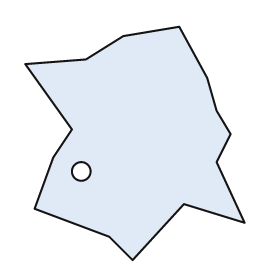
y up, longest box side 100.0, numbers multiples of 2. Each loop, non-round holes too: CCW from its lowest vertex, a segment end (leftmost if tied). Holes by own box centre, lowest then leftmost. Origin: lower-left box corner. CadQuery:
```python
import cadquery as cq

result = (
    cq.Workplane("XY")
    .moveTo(46.0, 0.0)
    .lineTo(68.0, 24.0)
    .lineTo(94.0, 16.0)
    .lineTo(82.0, 42.0)
    .lineTo(88.0, 54.0)
    .lineTo(82.0, 64.0)
    .lineTo(78.0, 78.0)
    .lineTo(66.0, 100.0)
    .lineTo(42.0, 96.0)
    .lineTo(26.0, 86.0)
    .lineTo(0.0, 84.0)
    .lineTo(20.0, 56.0)
    .lineTo(12.0, 44.0)
    .lineTo(4.0, 22.0)
    .lineTo(36.0, 10.0)
    .close()
    .moveTo(24.0, 38.0)
    .circle(4.0)
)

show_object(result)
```